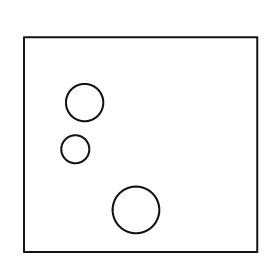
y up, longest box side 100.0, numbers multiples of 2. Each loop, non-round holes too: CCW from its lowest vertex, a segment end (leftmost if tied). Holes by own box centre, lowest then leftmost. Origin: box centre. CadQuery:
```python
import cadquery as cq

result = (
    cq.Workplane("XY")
    .moveTo(-50.0, -46.0)
    .lineTo(50.0, -46.0)
    .lineTo(50.0, 46.0)
    .lineTo(-50.0, 46.0)
    .close()
    .moveTo(-2.0, -28.0)
    .circle(10.0)
    .moveTo(-28.0, -2.0)
    .circle(6.0)
    .moveTo(-24.0, 18.0)
    .circle(8.0)
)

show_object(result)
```